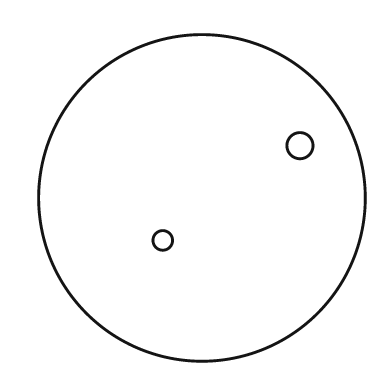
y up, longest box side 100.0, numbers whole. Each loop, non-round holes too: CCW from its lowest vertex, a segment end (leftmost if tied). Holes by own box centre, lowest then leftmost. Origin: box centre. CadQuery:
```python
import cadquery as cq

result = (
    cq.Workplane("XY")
    .moveTo(0.0, 0.0)
    .circle(50.0)
    .moveTo(-12.0, -13.0)
    .circle(3.0)
    .moveTo(30.0, 16.0)
    .circle(4.0)
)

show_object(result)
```